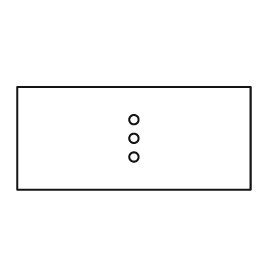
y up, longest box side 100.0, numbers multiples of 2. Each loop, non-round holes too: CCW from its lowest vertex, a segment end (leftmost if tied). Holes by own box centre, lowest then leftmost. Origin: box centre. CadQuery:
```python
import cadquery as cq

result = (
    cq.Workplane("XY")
    .moveTo(-50.0, -22.0)
    .lineTo(50.0, -22.0)
    .lineTo(50.0, 22.0)
    .lineTo(-50.0, 22.0)
    .close()
    .moveTo(0.0, -8.0)
    .circle(2.0)
    .moveTo(0.0, 0.0)
    .circle(2.0)
    .moveTo(0.0, 8.0)
    .circle(2.0)
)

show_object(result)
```